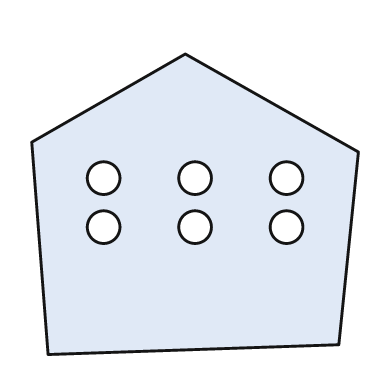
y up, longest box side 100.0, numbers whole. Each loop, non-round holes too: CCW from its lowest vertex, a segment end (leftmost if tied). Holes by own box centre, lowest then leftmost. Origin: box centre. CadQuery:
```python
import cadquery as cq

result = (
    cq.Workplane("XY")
    .moveTo(-45.0, -46.0)
    .lineTo(44.0, -43.0)
    .lineTo(50.0, 16.0)
    .lineTo(-3.0, 46.0)
    .lineTo(-50.0, 19.0)
    .close()
    .moveTo(-28.0, -7.0)
    .circle(5.0)
    .moveTo(0.0, -7.0)
    .circle(5.0)
    .moveTo(28.0, -7.0)
    .circle(5.0)
    .moveTo(-28.0, 8.0)
    .circle(5.0)
    .moveTo(0.0, 8.0)
    .circle(5.0)
    .moveTo(28.0, 8.0)
    .circle(5.0)
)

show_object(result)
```